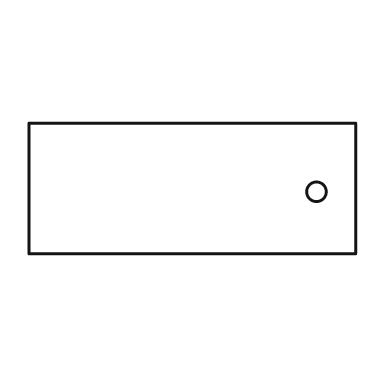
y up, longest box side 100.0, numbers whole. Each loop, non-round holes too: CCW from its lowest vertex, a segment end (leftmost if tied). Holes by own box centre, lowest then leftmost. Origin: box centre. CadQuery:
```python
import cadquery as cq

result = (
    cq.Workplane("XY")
    .moveTo(-50.0, -20.0)
    .lineTo(50.0, -20.0)
    .lineTo(50.0, 20.0)
    .lineTo(-50.0, 20.0)
    .close()
    .moveTo(38.0, -1.0)
    .circle(3.0)
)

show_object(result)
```